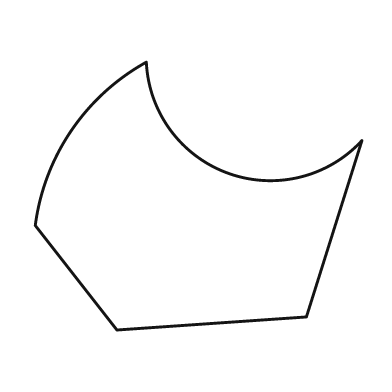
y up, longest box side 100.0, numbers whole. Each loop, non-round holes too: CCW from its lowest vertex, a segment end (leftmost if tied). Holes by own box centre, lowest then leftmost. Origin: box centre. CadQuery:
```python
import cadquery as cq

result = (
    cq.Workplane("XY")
    .moveTo(-25.0, -41.0)
    .lineTo(33.0, -37.0)
    .lineTo(50.0, 17.0)
    .threePointArc((9.0, 7.0), (-16.0, 41.0))
    .threePointArc((-39.0, 20.0), (-50.0, -9.0))
    .close()
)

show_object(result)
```